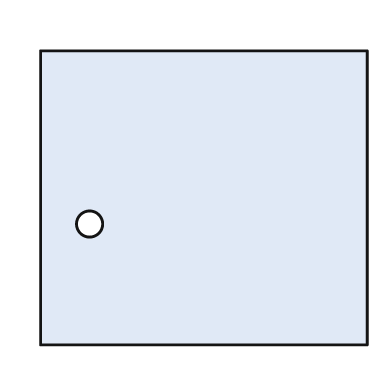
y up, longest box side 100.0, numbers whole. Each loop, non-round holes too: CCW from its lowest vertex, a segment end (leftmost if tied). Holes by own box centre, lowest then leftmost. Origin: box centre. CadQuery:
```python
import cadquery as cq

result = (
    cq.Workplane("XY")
    .moveTo(-50.0, -45.0)
    .lineTo(50.0, -45.0)
    .lineTo(50.0, 45.0)
    .lineTo(-50.0, 45.0)
    .close()
    .moveTo(-35.0, -8.0)
    .circle(4.0)
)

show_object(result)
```